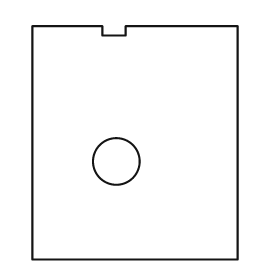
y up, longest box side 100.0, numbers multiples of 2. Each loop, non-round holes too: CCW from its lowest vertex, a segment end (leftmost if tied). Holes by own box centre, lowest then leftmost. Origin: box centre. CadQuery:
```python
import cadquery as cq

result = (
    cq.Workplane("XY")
    .moveTo(-44.0, -50.0)
    .lineTo(44.0, -50.0)
    .lineTo(44.0, 50.0)
    .lineTo(-4.0, 50.0)
    .lineTo(-4.0, 46.0)
    .lineTo(-14.0, 46.0)
    .lineTo(-14.0, 50.0)
    .lineTo(-44.0, 50.0)
    .close()
    .moveTo(-8.0, -8.0)
    .circle(10.0)
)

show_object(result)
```